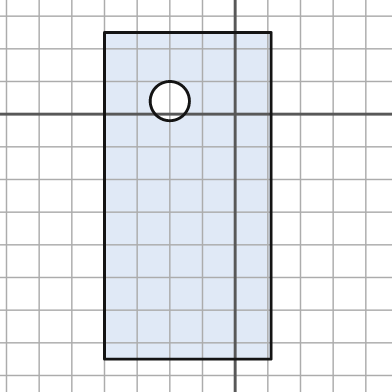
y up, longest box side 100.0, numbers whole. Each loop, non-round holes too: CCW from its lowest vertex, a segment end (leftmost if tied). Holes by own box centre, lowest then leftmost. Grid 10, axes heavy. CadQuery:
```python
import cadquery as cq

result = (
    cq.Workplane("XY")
    .moveTo(-40.0, -75.0)
    .lineTo(11.0, -75.0)
    .lineTo(11.0, 25.0)
    .lineTo(-40.0, 25.0)
    .close()
    .moveTo(-20.0, 4.0)
    .circle(6.0)
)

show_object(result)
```